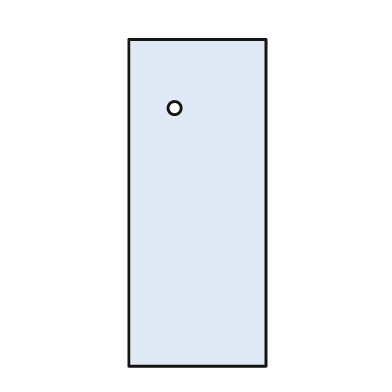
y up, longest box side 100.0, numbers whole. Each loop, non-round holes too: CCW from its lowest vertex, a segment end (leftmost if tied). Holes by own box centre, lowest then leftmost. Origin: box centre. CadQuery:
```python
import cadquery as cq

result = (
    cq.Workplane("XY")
    .moveTo(-21.0, -50.0)
    .lineTo(21.0, -50.0)
    .lineTo(21.0, 50.0)
    .lineTo(-21.0, 50.0)
    .close()
    .moveTo(-7.0, 29.0)
    .circle(2.0)
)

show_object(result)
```